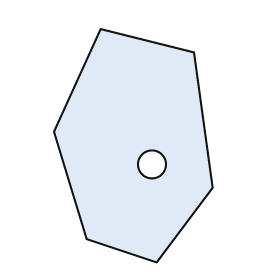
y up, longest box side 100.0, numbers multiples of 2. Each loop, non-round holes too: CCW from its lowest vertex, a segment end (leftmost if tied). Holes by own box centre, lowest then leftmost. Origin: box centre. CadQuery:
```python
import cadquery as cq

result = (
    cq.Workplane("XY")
    .moveTo(10.0, -50.0)
    .lineTo(34.0, -18.0)
    .lineTo(26.0, 40.0)
    .lineTo(-14.0, 50.0)
    .lineTo(-34.0, 6.0)
    .lineTo(-20.0, -40.0)
    .close()
    .moveTo(8.0, -8.0)
    .circle(6.0)
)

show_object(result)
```